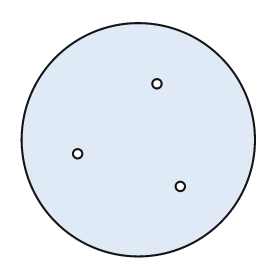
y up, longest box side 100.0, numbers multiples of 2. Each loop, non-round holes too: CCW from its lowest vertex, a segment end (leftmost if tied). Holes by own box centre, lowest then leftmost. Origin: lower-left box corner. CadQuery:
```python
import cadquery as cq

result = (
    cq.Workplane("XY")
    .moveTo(50.0, 50.0)
    .circle(50.0)
    .moveTo(68.0, 30.0)
    .circle(2.0)
    .moveTo(24.0, 44.0)
    .circle(2.0)
    .moveTo(58.0, 74.0)
    .circle(2.0)
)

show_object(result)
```